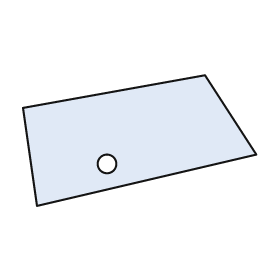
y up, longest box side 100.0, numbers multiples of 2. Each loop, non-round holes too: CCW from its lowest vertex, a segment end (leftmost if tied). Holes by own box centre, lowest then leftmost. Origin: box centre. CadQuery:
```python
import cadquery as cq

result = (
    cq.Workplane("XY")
    .moveTo(-44.0, -28.0)
    .lineTo(50.0, -6.0)
    .lineTo(28.0, 28.0)
    .lineTo(-50.0, 14.0)
    .close()
    .moveTo(-14.0, -10.0)
    .circle(4.0)
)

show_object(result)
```